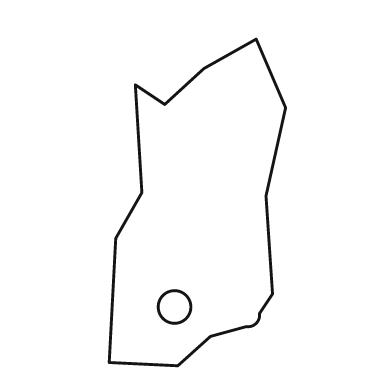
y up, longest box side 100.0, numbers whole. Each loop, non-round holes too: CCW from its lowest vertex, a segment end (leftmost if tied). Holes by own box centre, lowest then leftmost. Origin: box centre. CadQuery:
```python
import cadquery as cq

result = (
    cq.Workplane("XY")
    .moveTo(-6.0, -50.0)
    .lineTo(4.0, -41.0)
    .lineTo(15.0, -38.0)
    .threePointArc((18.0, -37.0), (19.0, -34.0))
    .lineTo(23.0, -28.0)
    .lineTo(21.0, 2.0)
    .lineTo(27.0, 29.0)
    .lineTo(18.0, 50.0)
    .lineTo(2.0, 41.0)
    .lineTo(-10.0, 30.0)
    .lineTo(-19.0, 36.0)
    .lineTo(-17.0, 3.0)
    .lineTo(-25.0, -11.0)
    .lineTo(-27.0, -49.0)
    .close()
    .moveTo(-7.0, -32.0)
    .circle(5.0)
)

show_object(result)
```